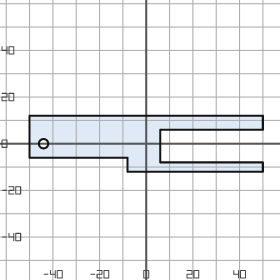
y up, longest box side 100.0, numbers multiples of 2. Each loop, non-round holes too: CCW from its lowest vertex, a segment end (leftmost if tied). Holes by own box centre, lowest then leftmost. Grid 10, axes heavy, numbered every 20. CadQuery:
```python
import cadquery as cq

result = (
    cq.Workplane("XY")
    .moveTo(-8.0, -12.0)
    .lineTo(50.0, -12.0)
    .lineTo(50.0, -8.0)
    .lineTo(6.0, -8.0)
    .lineTo(6.0, 6.0)
    .lineTo(50.0, 6.0)
    .lineTo(50.0, 12.0)
    .lineTo(-50.0, 12.0)
    .lineTo(-50.0, -6.0)
    .lineTo(-8.0, -6.0)
    .close()
    .moveTo(-44.0, 0.0)
    .circle(2.0)
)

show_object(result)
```